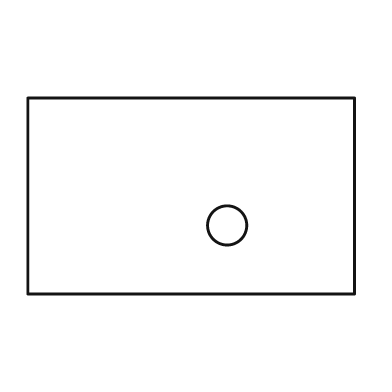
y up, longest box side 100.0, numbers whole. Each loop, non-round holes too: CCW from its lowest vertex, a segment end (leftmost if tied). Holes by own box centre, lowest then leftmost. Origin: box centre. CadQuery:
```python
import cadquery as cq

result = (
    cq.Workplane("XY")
    .moveTo(-50.0, -30.0)
    .lineTo(50.0, -30.0)
    .lineTo(50.0, 30.0)
    .lineTo(-50.0, 30.0)
    .close()
    .moveTo(11.0, -9.0)
    .circle(6.0)
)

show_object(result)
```